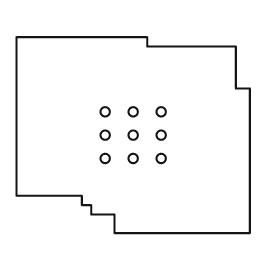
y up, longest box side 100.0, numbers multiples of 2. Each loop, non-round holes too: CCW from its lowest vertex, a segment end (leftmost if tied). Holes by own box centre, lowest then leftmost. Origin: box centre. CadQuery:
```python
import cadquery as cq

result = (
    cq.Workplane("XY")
    .moveTo(-8.0, -42.0)
    .lineTo(50.0, -42.0)
    .lineTo(50.0, 20.0)
    .lineTo(44.0, 20.0)
    .lineTo(44.0, 38.0)
    .lineTo(6.0, 38.0)
    .lineTo(6.0, 42.0)
    .lineTo(-50.0, 42.0)
    .lineTo(-50.0, -26.0)
    .lineTo(-22.0, -26.0)
    .lineTo(-22.0, -30.0)
    .lineTo(-18.0, -30.0)
    .lineTo(-18.0, -34.0)
    .lineTo(-8.0, -34.0)
    .close()
    .moveTo(-12.0, -10.0)
    .circle(2.0)
    .moveTo(0.0, -10.0)
    .circle(2.0)
    .moveTo(12.0, -10.0)
    .circle(2.0)
    .moveTo(-12.0, 0.0)
    .circle(2.0)
    .moveTo(0.0, 0.0)
    .circle(2.0)
    .moveTo(12.0, 0.0)
    .circle(2.0)
    .moveTo(-12.0, 10.0)
    .circle(2.0)
    .moveTo(0.0, 10.0)
    .circle(2.0)
    .moveTo(12.0, 10.0)
    .circle(2.0)
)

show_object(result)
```